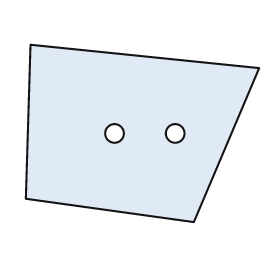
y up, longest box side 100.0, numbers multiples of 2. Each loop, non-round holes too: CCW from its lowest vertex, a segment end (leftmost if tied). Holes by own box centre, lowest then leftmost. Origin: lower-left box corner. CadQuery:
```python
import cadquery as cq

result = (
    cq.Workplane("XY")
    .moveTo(72.0, 0.0)
    .lineTo(100.0, 66.0)
    .lineTo(2.0, 76.0)
    .lineTo(0.0, 10.0)
    .close()
    .moveTo(38.0, 38.0)
    .circle(4.0)
    .moveTo(64.0, 38.0)
    .circle(4.0)
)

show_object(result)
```